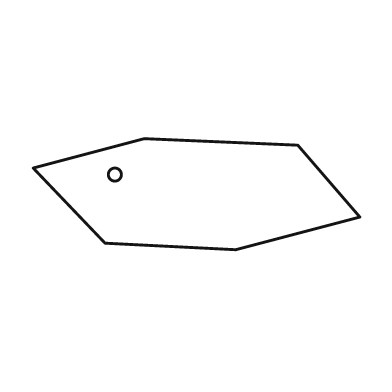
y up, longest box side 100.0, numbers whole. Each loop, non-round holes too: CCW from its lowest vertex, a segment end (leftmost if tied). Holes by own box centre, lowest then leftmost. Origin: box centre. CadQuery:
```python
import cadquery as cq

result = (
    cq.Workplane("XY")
    .moveTo(12.0, -17.0)
    .lineTo(50.0, -7.0)
    .lineTo(31.0, 15.0)
    .lineTo(-16.0, 17.0)
    .lineTo(-50.0, 8.0)
    .lineTo(-28.0, -15.0)
    .close()
    .moveTo(-25.0, 6.0)
    .circle(2.0)
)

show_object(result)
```